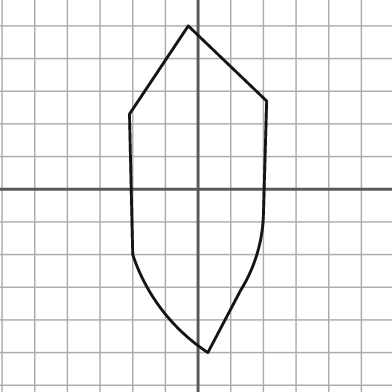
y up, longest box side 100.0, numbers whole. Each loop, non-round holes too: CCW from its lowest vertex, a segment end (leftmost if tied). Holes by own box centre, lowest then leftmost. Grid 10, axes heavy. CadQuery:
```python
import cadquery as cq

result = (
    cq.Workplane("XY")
    .moveTo(3.0, -50.0)
    .lineTo(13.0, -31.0)
    .threePointArc((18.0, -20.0), (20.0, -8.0))
    .lineTo(21.0, 27.0)
    .lineTo(-3.0, 50.0)
    .lineTo(-21.0, 23.0)
    .lineTo(-20.0, -20.0)
    .threePointArc((-11.0, -37.0), (3.0, -50.0))
    .close()
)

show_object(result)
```